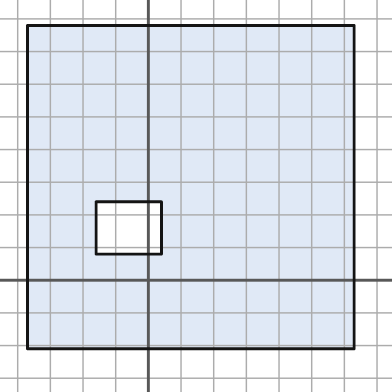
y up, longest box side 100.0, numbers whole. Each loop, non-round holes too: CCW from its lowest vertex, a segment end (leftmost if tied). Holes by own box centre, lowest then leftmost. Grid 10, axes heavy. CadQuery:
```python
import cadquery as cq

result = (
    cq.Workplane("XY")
    .moveTo(-37.0, -21.0)
    .lineTo(63.0, -21.0)
    .lineTo(63.0, 78.0)
    .lineTo(-37.0, 78.0)
    .close()
    .moveTo(-16.0, 8.0)
    .lineTo(4.0, 8.0)
    .lineTo(4.0, 24.0)
    .lineTo(-16.0, 24.0)
    .close()
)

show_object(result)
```